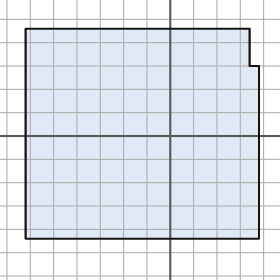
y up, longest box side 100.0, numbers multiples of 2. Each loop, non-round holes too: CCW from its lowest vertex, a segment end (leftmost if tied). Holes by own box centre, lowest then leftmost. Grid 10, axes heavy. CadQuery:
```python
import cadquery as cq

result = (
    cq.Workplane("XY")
    .moveTo(-62.0, -44.0)
    .lineTo(38.0, -44.0)
    .lineTo(38.0, 30.0)
    .lineTo(34.0, 30.0)
    .lineTo(34.0, 46.0)
    .lineTo(-62.0, 46.0)
    .close()
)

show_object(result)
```